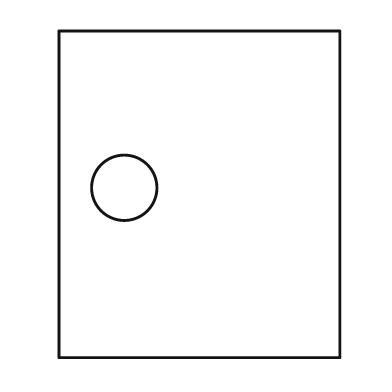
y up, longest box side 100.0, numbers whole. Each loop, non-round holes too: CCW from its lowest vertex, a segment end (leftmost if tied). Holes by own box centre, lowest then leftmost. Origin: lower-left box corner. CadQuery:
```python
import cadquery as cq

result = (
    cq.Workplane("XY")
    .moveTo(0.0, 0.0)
    .lineTo(86.0, 0.0)
    .lineTo(86.0, 100.0)
    .lineTo(0.0, 100.0)
    .close()
    .moveTo(20.0, 52.0)
    .circle(10.0)
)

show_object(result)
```